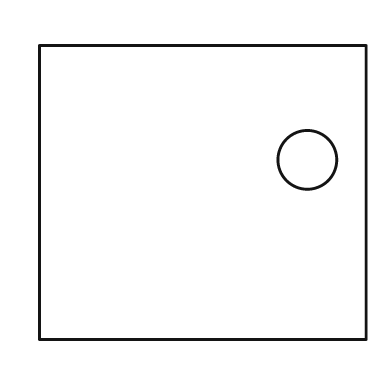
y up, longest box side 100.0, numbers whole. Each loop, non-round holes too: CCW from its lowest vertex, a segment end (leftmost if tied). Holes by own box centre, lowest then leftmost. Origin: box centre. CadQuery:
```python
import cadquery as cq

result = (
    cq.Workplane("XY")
    .moveTo(-50.0, -45.0)
    .lineTo(50.0, -45.0)
    .lineTo(50.0, 45.0)
    .lineTo(-50.0, 45.0)
    .close()
    .moveTo(32.0, 10.0)
    .circle(9.0)
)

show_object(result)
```